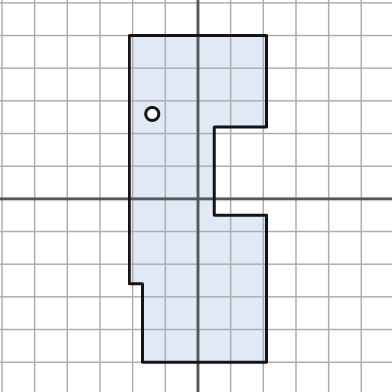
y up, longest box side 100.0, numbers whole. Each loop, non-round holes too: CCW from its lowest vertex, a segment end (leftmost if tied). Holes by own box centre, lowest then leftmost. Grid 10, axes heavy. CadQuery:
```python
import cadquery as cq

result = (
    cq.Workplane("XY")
    .moveTo(-17.0, -50.0)
    .lineTo(21.0, -50.0)
    .lineTo(21.0, -5.0)
    .lineTo(5.0, -5.0)
    .lineTo(5.0, 22.0)
    .lineTo(21.0, 22.0)
    .lineTo(21.0, 50.0)
    .lineTo(-21.0, 50.0)
    .lineTo(-21.0, -26.0)
    .lineTo(-17.0, -26.0)
    .close()
    .moveTo(-14.0, 26.0)
    .circle(2.0)
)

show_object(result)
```